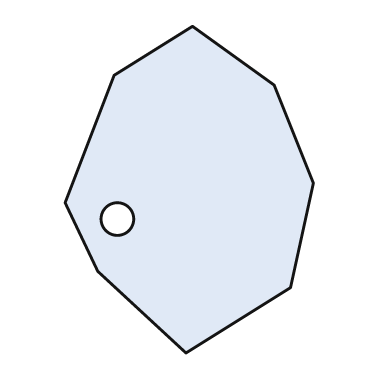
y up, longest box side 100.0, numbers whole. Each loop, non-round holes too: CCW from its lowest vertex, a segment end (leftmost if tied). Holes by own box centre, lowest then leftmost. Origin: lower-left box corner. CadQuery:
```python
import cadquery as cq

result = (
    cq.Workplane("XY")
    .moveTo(37.0, 0.0)
    .lineTo(69.0, 20.0)
    .lineTo(76.0, 52.0)
    .lineTo(64.0, 82.0)
    .lineTo(39.0, 100.0)
    .lineTo(15.0, 85.0)
    .lineTo(0.0, 46.0)
    .lineTo(10.0, 25.0)
    .close()
    .moveTo(16.0, 41.0)
    .circle(5.0)
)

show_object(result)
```